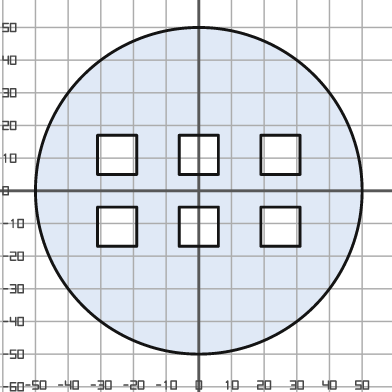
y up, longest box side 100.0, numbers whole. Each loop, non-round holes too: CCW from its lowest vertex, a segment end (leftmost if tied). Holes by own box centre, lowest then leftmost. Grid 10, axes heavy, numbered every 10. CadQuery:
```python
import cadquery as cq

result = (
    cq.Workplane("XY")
    .moveTo(0.0, 0.0)
    .circle(50.0)
    .moveTo(-31.0, -17.0)
    .lineTo(-19.0, -17.0)
    .lineTo(-19.0, -5.0)
    .lineTo(-31.0, -5.0)
    .close()
    .moveTo(-6.0, -17.0)
    .lineTo(6.0, -17.0)
    .lineTo(6.0, -5.0)
    .lineTo(-6.0, -5.0)
    .close()
    .moveTo(19.0, -17.0)
    .lineTo(31.0, -17.0)
    .lineTo(31.0, -5.0)
    .lineTo(19.0, -5.0)
    .close()
    .moveTo(-31.0, 5.0)
    .lineTo(-19.0, 5.0)
    .lineTo(-19.0, 17.0)
    .lineTo(-31.0, 17.0)
    .close()
    .moveTo(-6.0, 5.0)
    .lineTo(6.0, 5.0)
    .lineTo(6.0, 17.0)
    .lineTo(-6.0, 17.0)
    .close()
    .moveTo(19.0, 5.0)
    .lineTo(31.0, 5.0)
    .lineTo(31.0, 17.0)
    .lineTo(19.0, 17.0)
    .close()
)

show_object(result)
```